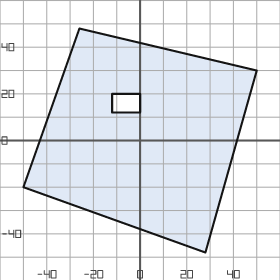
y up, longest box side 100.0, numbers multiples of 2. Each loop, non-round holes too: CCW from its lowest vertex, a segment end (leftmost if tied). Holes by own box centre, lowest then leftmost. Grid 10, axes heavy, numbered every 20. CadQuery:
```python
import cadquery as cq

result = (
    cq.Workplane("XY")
    .moveTo(28.0, -48.0)
    .lineTo(50.0, 30.0)
    .lineTo(-26.0, 48.0)
    .lineTo(-50.0, -20.0)
    .close()
    .moveTo(-12.0, 12.0)
    .lineTo(0.0, 12.0)
    .lineTo(0.0, 20.0)
    .lineTo(-12.0, 20.0)
    .close()
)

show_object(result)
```